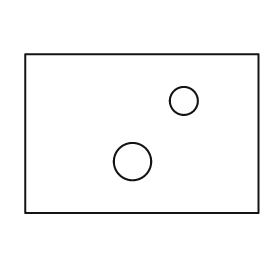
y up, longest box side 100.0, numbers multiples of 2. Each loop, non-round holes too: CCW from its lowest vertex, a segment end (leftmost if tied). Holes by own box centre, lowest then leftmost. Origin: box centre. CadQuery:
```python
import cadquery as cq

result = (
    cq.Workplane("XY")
    .moveTo(-50.0, -34.0)
    .lineTo(50.0, -34.0)
    .lineTo(50.0, 34.0)
    .lineTo(-50.0, 34.0)
    .close()
    .moveTo(-4.0, -12.0)
    .circle(8.0)
    .moveTo(18.0, 14.0)
    .circle(6.0)
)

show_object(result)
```